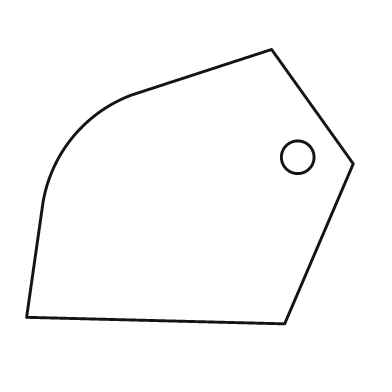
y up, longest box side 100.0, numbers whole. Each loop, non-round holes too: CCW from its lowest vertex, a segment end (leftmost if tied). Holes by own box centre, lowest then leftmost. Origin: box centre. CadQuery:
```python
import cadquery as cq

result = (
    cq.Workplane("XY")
    .moveTo(29.0, -42.0)
    .lineTo(50.0, 7.0)
    .lineTo(25.0, 42.0)
    .lineTo(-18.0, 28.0)
    .threePointArc((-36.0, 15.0), (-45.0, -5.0))
    .lineTo(-50.0, -40.0)
    .close()
    .moveTo(33.0, 9.0)
    .circle(5.0)
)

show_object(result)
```